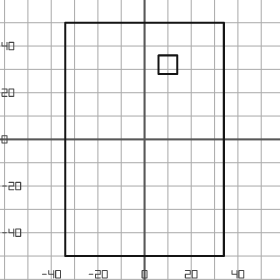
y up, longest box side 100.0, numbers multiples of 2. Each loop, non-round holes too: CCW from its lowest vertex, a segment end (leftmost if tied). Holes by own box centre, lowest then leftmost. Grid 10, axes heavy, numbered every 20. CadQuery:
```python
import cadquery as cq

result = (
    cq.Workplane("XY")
    .moveTo(-34.0, -50.0)
    .lineTo(34.0, -50.0)
    .lineTo(34.0, 50.0)
    .lineTo(-34.0, 50.0)
    .close()
    .moveTo(6.0, 28.0)
    .lineTo(14.0, 28.0)
    .lineTo(14.0, 36.0)
    .lineTo(6.0, 36.0)
    .close()
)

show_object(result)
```